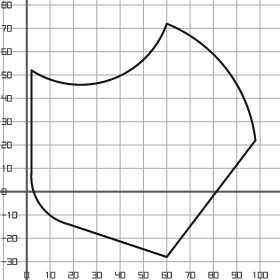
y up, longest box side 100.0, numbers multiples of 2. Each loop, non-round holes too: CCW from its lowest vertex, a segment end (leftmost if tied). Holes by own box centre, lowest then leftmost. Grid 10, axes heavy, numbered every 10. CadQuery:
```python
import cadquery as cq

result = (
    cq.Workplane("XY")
    .moveTo(60.0, -28.0)
    .lineTo(98.0, 22.0)
    .threePointArc((86.0, 52.0), (60.0, 72.0))
    .threePointArc((36.0, 48.0), (2.0, 52.0))
    .lineTo(2.0, 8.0)
    .threePointArc((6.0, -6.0), (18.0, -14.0))
    .close()
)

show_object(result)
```